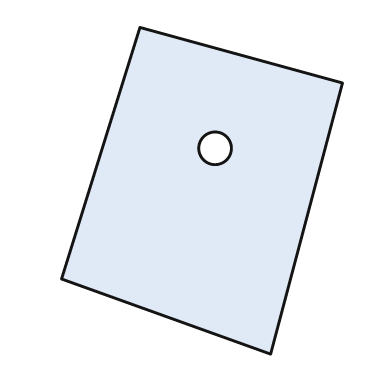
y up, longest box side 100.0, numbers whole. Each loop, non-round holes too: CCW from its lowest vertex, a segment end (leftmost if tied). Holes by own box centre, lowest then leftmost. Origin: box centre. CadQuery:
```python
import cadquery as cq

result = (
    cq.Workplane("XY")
    .moveTo(21.0, -50.0)
    .lineTo(43.0, 33.0)
    .lineTo(-19.0, 50.0)
    .lineTo(-43.0, -27.0)
    .close()
    .moveTo(4.0, 13.0)
    .circle(5.0)
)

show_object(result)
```